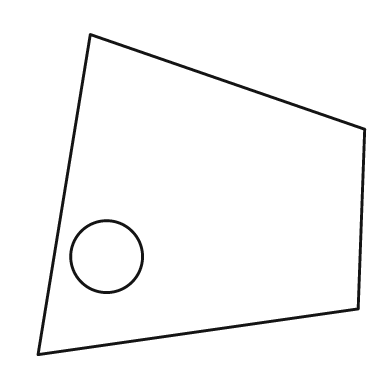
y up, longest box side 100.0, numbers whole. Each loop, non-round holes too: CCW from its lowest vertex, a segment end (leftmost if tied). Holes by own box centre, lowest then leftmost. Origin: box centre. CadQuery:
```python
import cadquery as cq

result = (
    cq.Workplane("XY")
    .moveTo(-50.0, -49.0)
    .lineTo(48.0, -35.0)
    .lineTo(50.0, 20.0)
    .lineTo(-34.0, 49.0)
    .close()
    .moveTo(-29.0, -19.0)
    .circle(11.0)
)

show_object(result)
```